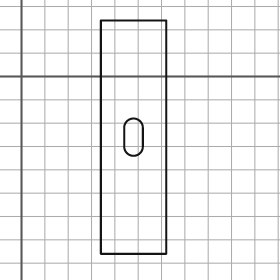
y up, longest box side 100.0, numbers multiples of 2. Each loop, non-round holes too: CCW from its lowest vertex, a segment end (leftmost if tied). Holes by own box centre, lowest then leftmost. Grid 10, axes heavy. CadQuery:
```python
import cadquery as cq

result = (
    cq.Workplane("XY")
    .moveTo(34.0, -76.0)
    .lineTo(62.0, -76.0)
    .lineTo(62.0, 24.0)
    .lineTo(34.0, 24.0)
    .close()
    .moveTo(44.0, -30.0)
    .threePointArc((48.0, -34.0), (52.0, -30.0))
    .lineTo(52.0, -22.0)
    .threePointArc((48.0, -18.0), (44.0, -22.0))
    .close()
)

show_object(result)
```